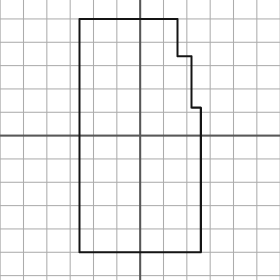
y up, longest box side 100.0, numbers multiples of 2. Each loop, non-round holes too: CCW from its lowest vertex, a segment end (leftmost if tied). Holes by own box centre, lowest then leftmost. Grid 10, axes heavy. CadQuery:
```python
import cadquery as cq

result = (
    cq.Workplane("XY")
    .moveTo(-26.0, -50.0)
    .lineTo(26.0, -50.0)
    .lineTo(26.0, 12.0)
    .lineTo(22.0, 12.0)
    .lineTo(22.0, 34.0)
    .lineTo(16.0, 34.0)
    .lineTo(16.0, 50.0)
    .lineTo(-26.0, 50.0)
    .close()
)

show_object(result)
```